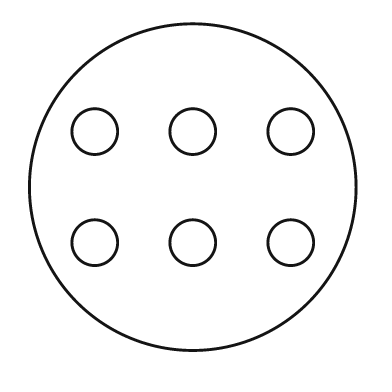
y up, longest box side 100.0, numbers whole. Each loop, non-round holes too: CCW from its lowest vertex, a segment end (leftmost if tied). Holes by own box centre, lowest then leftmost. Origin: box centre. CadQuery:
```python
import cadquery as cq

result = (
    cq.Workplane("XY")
    .moveTo(0.0, 0.0)
    .circle(50.0)
    .moveTo(-30.0, -17.0)
    .circle(7.0)
    .moveTo(0.0, -17.0)
    .circle(7.0)
    .moveTo(30.0, -17.0)
    .circle(7.0)
    .moveTo(-30.0, 17.0)
    .circle(7.0)
    .moveTo(0.0, 17.0)
    .circle(7.0)
    .moveTo(30.0, 17.0)
    .circle(7.0)
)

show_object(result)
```